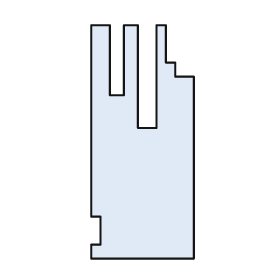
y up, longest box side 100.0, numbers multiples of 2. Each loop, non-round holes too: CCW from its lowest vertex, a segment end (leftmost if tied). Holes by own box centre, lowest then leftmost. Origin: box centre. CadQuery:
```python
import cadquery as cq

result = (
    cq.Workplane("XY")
    .moveTo(-22.0, -50.0)
    .lineTo(22.0, -50.0)
    .lineTo(22.0, 28.0)
    .lineTo(14.0, 28.0)
    .lineTo(14.0, 34.0)
    .lineTo(10.0, 34.0)
    .lineTo(10.0, 50.0)
    .lineTo(6.0, 50.0)
    .lineTo(6.0, 6.0)
    .lineTo(-2.0, 6.0)
    .lineTo(-2.0, 50.0)
    .lineTo(-8.0, 50.0)
    .lineTo(-8.0, 20.0)
    .lineTo(-14.0, 20.0)
    .lineTo(-14.0, 50.0)
    .lineTo(-22.0, 50.0)
    .lineTo(-22.0, -32.0)
    .lineTo(-18.0, -32.0)
    .lineTo(-18.0, -44.0)
    .lineTo(-22.0, -44.0)
    .close()
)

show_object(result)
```